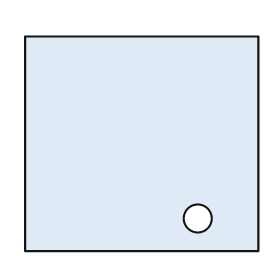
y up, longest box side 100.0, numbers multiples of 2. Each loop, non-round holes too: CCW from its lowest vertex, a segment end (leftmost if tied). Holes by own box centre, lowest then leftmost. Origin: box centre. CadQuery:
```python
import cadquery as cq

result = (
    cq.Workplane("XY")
    .moveTo(-50.0, -46.0)
    .lineTo(50.0, -46.0)
    .lineTo(50.0, 46.0)
    .lineTo(-50.0, 46.0)
    .close()
    .moveTo(24.0, -32.0)
    .circle(6.0)
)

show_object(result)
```